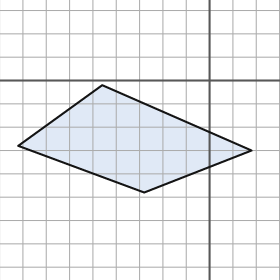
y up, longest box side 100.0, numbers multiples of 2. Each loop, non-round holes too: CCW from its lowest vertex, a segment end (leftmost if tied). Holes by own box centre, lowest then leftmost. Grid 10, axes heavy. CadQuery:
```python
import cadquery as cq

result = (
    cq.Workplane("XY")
    .moveTo(-28.0, -48.0)
    .lineTo(18.0, -30.0)
    .lineTo(-46.0, -2.0)
    .lineTo(-82.0, -28.0)
    .close()
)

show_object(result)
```